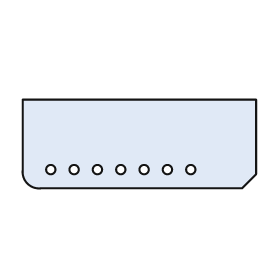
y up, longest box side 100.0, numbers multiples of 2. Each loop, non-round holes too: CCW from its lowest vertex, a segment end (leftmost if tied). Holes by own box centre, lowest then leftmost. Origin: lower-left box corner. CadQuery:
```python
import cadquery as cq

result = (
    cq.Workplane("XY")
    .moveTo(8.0, 0.0)
    .lineTo(94.0, 0.0)
    .lineTo(100.0, 6.0)
    .lineTo(100.0, 38.0)
    .lineTo(0.0, 38.0)
    .lineTo(0.0, 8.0)
    .threePointArc((2.0, 2.0), (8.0, 0.0))
    .close()
    .moveTo(12.0, 8.0)
    .circle(2.0)
    .moveTo(22.0, 8.0)
    .circle(2.0)
    .moveTo(32.0, 8.0)
    .circle(2.0)
    .moveTo(42.0, 8.0)
    .circle(2.0)
    .moveTo(52.0, 8.0)
    .circle(2.0)
    .moveTo(62.0, 8.0)
    .circle(2.0)
    .moveTo(72.0, 8.0)
    .circle(2.0)
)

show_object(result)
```